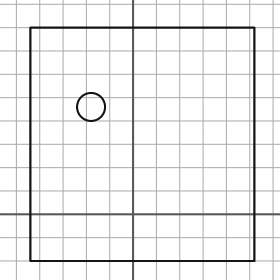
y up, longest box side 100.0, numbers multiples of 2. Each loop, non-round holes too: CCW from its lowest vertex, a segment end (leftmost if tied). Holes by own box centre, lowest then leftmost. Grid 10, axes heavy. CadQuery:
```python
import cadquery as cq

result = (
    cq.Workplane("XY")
    .moveTo(-44.0, -20.0)
    .lineTo(52.0, -20.0)
    .lineTo(52.0, 80.0)
    .lineTo(-44.0, 80.0)
    .close()
    .moveTo(-18.0, 46.0)
    .circle(6.0)
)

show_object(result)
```